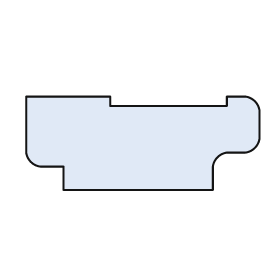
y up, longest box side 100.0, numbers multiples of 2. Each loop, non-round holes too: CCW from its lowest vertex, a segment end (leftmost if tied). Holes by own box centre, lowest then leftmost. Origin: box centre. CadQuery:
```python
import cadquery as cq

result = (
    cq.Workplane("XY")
    .moveTo(-34.0, -20.0)
    .lineTo(30.0, -20.0)
    .lineTo(30.0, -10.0)
    .threePointArc((32.0, -6.0), (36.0, -4.0))
    .lineTo(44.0, -4.0)
    .threePointArc((48.0, -2.0), (50.0, 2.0))
    .lineTo(50.0, 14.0)
    .threePointArc((48.0, 18.0), (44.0, 20.0))
    .lineTo(36.0, 20.0)
    .lineTo(36.0, 16.0)
    .lineTo(-14.0, 16.0)
    .lineTo(-14.0, 20.0)
    .lineTo(-50.0, 20.0)
    .lineTo(-50.0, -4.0)
    .threePointArc((-48.0, -8.0), (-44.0, -10.0))
    .lineTo(-34.0, -10.0)
    .close()
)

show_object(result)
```